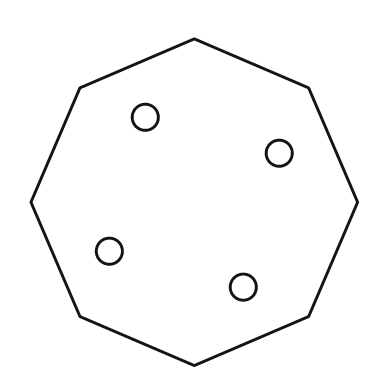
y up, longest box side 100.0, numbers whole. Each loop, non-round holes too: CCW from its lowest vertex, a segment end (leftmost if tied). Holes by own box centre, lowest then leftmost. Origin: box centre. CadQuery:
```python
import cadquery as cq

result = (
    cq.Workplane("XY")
    .moveTo(0.0, -50.0)
    .lineTo(35.0, -35.0)
    .lineTo(50.0, 0.0)
    .lineTo(35.0, 35.0)
    .lineTo(0.0, 50.0)
    .lineTo(-35.0, 35.0)
    .lineTo(-50.0, 0.0)
    .lineTo(-35.0, -35.0)
    .close()
    .moveTo(15.0, -26.0)
    .circle(4.0)
    .moveTo(-26.0, -15.0)
    .circle(4.0)
    .moveTo(26.0, 15.0)
    .circle(4.0)
    .moveTo(-15.0, 26.0)
    .circle(4.0)
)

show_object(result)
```